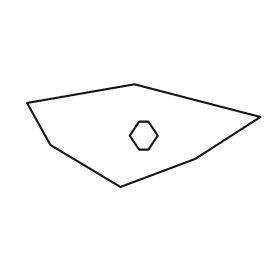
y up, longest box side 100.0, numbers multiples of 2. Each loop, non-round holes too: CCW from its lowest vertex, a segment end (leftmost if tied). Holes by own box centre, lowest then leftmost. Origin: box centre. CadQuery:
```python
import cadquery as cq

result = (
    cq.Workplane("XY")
    .moveTo(-10.0, -22.0)
    .lineTo(22.0, -10.0)
    .lineTo(50.0, 8.0)
    .lineTo(-4.0, 22.0)
    .lineTo(-50.0, 14.0)
    .lineTo(-40.0, -4.0)
    .close()
    .moveTo(-2.0, -6.0)
    .lineTo(2.0, -6.0)
    .lineTo(6.0, 0.0)
    .lineTo(2.0, 6.0)
    .lineTo(-2.0, 6.0)
    .lineTo(-6.0, 0.0)
    .close()
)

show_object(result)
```